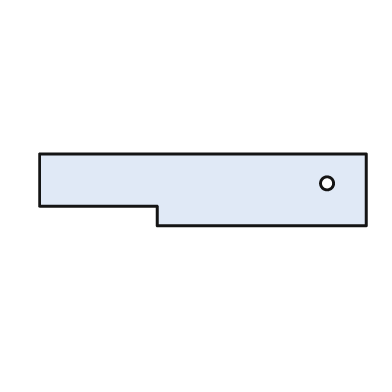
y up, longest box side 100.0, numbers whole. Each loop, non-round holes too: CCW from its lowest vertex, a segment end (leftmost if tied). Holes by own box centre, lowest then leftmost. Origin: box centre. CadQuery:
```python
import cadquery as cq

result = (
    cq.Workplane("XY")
    .moveTo(-14.0, -11.0)
    .lineTo(50.0, -11.0)
    .lineTo(50.0, 11.0)
    .lineTo(-50.0, 11.0)
    .lineTo(-50.0, -5.0)
    .lineTo(-14.0, -5.0)
    .close()
    .moveTo(38.0, 2.0)
    .circle(2.0)
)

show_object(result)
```